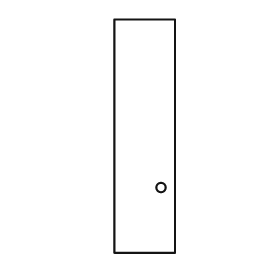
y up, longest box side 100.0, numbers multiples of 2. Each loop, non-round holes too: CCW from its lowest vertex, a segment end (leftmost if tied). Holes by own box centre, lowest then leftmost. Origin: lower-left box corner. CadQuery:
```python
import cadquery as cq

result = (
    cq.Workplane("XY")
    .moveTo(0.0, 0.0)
    .lineTo(26.0, 0.0)
    .lineTo(26.0, 100.0)
    .lineTo(0.0, 100.0)
    .close()
    .moveTo(20.0, 28.0)
    .circle(2.0)
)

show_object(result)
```